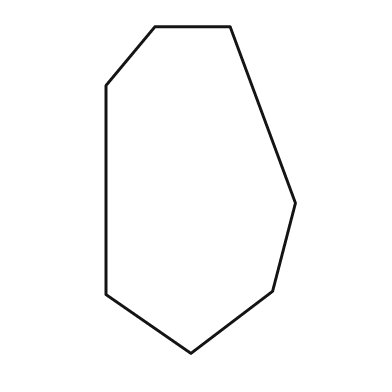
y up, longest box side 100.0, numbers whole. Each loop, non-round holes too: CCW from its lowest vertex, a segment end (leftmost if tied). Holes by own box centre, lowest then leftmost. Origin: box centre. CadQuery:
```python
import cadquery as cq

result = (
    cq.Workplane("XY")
    .moveTo(-3.0, -50.0)
    .lineTo(22.0, -31.0)
    .lineTo(29.0, -4.0)
    .lineTo(9.0, 50.0)
    .lineTo(-14.0, 50.0)
    .lineTo(-29.0, 32.0)
    .lineTo(-29.0, -32.0)
    .close()
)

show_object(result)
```